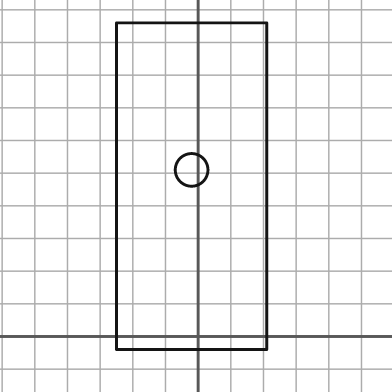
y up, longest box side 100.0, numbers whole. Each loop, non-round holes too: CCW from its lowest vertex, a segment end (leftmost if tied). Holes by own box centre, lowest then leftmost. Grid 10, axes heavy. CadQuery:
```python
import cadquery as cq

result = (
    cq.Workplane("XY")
    .moveTo(-25.0, -4.0)
    .lineTo(21.0, -4.0)
    .lineTo(21.0, 96.0)
    .lineTo(-25.0, 96.0)
    .close()
    .moveTo(-2.0, 51.0)
    .circle(5.0)
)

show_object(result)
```